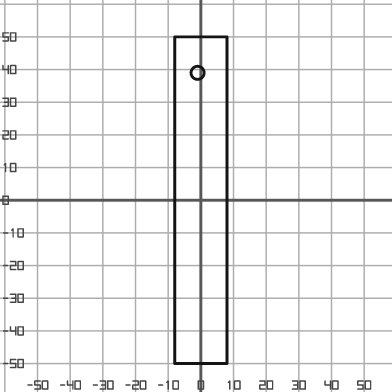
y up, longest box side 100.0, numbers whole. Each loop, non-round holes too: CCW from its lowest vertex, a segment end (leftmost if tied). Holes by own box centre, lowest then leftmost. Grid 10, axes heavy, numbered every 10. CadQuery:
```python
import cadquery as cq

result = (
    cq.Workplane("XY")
    .moveTo(-8.0, -50.0)
    .lineTo(8.0, -50.0)
    .lineTo(8.0, 50.0)
    .lineTo(-8.0, 50.0)
    .close()
    .moveTo(-1.0, 39.0)
    .circle(2.0)
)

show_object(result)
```